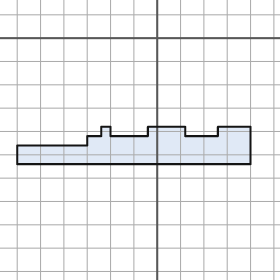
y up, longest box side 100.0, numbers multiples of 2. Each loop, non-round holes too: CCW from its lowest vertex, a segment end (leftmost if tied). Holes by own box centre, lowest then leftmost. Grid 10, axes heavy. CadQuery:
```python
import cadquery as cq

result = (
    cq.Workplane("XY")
    .moveTo(-60.0, -54.0)
    .lineTo(40.0, -54.0)
    .lineTo(40.0, -38.0)
    .lineTo(26.0, -38.0)
    .lineTo(26.0, -42.0)
    .lineTo(12.0, -42.0)
    .lineTo(12.0, -38.0)
    .lineTo(-4.0, -38.0)
    .lineTo(-4.0, -42.0)
    .lineTo(-20.0, -42.0)
    .lineTo(-20.0, -38.0)
    .lineTo(-24.0, -38.0)
    .lineTo(-24.0, -42.0)
    .lineTo(-30.0, -42.0)
    .lineTo(-30.0, -46.0)
    .lineTo(-60.0, -46.0)
    .close()
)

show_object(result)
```